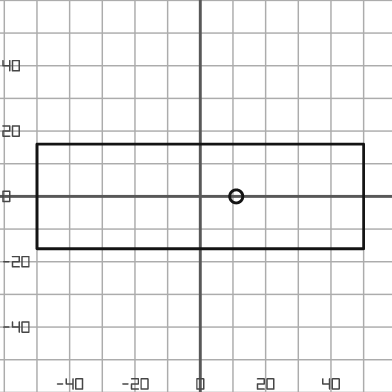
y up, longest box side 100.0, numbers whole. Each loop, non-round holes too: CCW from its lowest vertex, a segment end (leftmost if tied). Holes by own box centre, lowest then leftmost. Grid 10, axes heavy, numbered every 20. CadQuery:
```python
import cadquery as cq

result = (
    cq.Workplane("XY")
    .moveTo(-50.0, -16.0)
    .lineTo(50.0, -16.0)
    .lineTo(50.0, 16.0)
    .lineTo(-50.0, 16.0)
    .close()
    .moveTo(11.0, 0.0)
    .circle(2.0)
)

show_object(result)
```